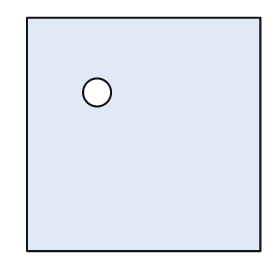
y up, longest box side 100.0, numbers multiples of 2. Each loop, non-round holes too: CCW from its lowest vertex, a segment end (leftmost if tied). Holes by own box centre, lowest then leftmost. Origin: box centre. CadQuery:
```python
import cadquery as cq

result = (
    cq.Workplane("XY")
    .moveTo(-50.0, -50.0)
    .lineTo(50.0, -50.0)
    .lineTo(50.0, 50.0)
    .lineTo(-50.0, 50.0)
    .close()
    .moveTo(-20.0, 18.0)
    .circle(6.0)
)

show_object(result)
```